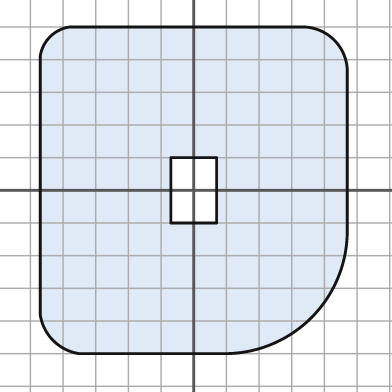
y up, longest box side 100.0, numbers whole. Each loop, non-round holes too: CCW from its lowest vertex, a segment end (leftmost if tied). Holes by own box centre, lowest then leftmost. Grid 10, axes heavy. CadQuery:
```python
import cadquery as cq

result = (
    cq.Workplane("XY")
    .moveTo(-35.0, -50.0)
    .lineTo(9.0, -50.0)
    .threePointArc((36.0, -39.0), (47.0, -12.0))
    .lineTo(47.0, 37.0)
    .threePointArc((43.0, 46.0), (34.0, 50.0))
    .lineTo(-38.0, 50.0)
    .threePointArc((-44.0, 47.0), (-47.0, 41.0))
    .lineTo(-47.0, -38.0)
    .threePointArc((-43.0, -46.0), (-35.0, -50.0))
    .close()
    .moveTo(-7.0, -10.0)
    .lineTo(7.0, -10.0)
    .lineTo(7.0, 10.0)
    .lineTo(-7.0, 10.0)
    .close()
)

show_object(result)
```